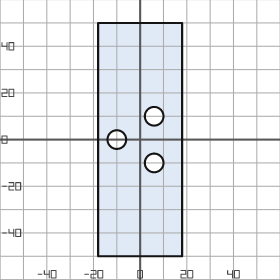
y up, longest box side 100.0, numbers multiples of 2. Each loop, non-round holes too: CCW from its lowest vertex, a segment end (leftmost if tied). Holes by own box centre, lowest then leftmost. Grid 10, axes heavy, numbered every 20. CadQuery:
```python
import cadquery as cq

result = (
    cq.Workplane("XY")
    .moveTo(-18.0, -50.0)
    .lineTo(18.0, -50.0)
    .lineTo(18.0, 50.0)
    .lineTo(-18.0, 50.0)
    .close()
    .moveTo(6.0, -10.0)
    .circle(4.0)
    .moveTo(-10.0, 0.0)
    .circle(4.0)
    .moveTo(6.0, 10.0)
    .circle(4.0)
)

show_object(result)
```